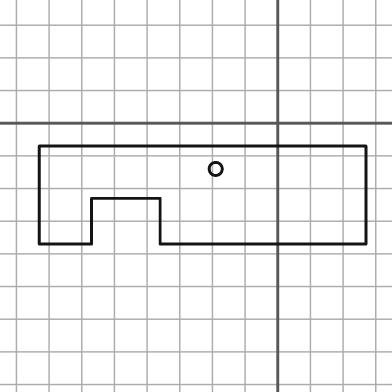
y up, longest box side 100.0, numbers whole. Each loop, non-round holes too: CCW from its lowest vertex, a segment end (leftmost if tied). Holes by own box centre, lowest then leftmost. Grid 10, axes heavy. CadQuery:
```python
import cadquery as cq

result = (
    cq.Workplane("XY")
    .moveTo(-73.0, -37.0)
    .lineTo(-57.0, -37.0)
    .lineTo(-57.0, -23.0)
    .lineTo(-36.0, -23.0)
    .lineTo(-36.0, -37.0)
    .lineTo(27.0, -37.0)
    .lineTo(27.0, -7.0)
    .lineTo(-73.0, -7.0)
    .close()
    .moveTo(-19.0, -14.0)
    .circle(2.0)
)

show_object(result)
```